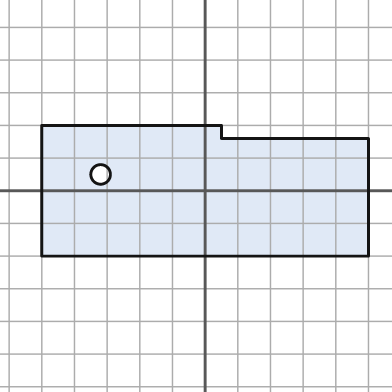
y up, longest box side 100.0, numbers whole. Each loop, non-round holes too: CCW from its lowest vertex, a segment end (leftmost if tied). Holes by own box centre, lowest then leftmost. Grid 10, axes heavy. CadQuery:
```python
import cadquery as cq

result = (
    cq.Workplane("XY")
    .moveTo(-50.0, -20.0)
    .lineTo(50.0, -20.0)
    .lineTo(50.0, 16.0)
    .lineTo(5.0, 16.0)
    .lineTo(5.0, 20.0)
    .lineTo(-50.0, 20.0)
    .close()
    .moveTo(-32.0, 5.0)
    .circle(3.0)
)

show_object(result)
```